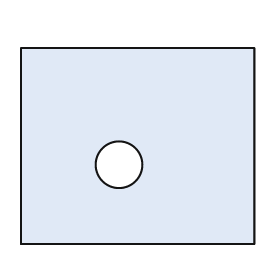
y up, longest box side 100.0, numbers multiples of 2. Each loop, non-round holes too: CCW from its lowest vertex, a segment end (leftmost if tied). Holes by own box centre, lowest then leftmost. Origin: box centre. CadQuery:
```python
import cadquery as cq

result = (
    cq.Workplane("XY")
    .moveTo(-50.0, -42.0)
    .lineTo(50.0, -42.0)
    .lineTo(50.0, 42.0)
    .lineTo(-50.0, 42.0)
    .close()
    .moveTo(-8.0, -8.0)
    .circle(10.0)
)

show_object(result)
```